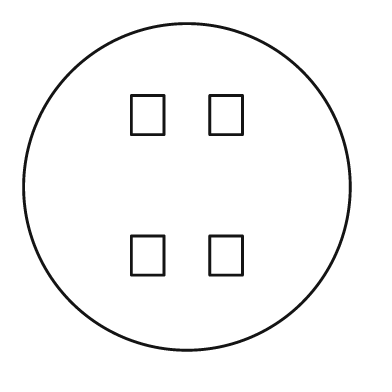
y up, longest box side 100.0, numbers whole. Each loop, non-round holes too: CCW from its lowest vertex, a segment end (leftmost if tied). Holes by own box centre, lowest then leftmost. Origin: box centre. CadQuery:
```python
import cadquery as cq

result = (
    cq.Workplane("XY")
    .moveTo(0.0, 0.0)
    .circle(50.0)
    .moveTo(-17.0, -27.0)
    .lineTo(-7.0, -27.0)
    .lineTo(-7.0, -15.0)
    .lineTo(-17.0, -15.0)
    .close()
    .moveTo(7.0, -27.0)
    .lineTo(17.0, -27.0)
    .lineTo(17.0, -15.0)
    .lineTo(7.0, -15.0)
    .close()
    .moveTo(-17.0, 16.0)
    .lineTo(-7.0, 16.0)
    .lineTo(-7.0, 28.0)
    .lineTo(-17.0, 28.0)
    .close()
    .moveTo(7.0, 16.0)
    .lineTo(17.0, 16.0)
    .lineTo(17.0, 28.0)
    .lineTo(7.0, 28.0)
    .close()
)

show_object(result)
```